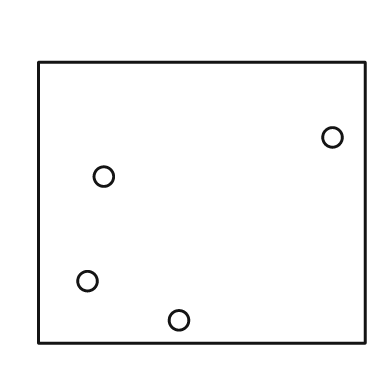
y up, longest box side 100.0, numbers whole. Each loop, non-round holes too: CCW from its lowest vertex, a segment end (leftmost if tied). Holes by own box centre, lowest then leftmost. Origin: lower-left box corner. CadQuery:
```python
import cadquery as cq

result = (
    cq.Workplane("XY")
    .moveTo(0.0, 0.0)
    .lineTo(100.0, 0.0)
    .lineTo(100.0, 86.0)
    .lineTo(0.0, 86.0)
    .close()
    .moveTo(43.0, 7.0)
    .circle(3.0)
    .moveTo(15.0, 19.0)
    .circle(3.0)
    .moveTo(20.0, 51.0)
    .circle(3.0)
    .moveTo(90.0, 63.0)
    .circle(3.0)
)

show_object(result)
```